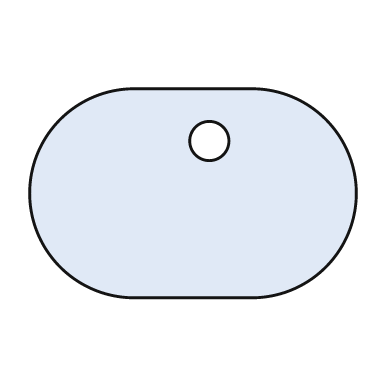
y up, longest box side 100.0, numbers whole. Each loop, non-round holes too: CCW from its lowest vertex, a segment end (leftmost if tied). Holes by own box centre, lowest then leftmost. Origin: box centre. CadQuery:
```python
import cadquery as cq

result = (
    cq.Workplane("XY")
    .moveTo(-18.0, -32.0)
    .lineTo(18.0, -32.0)
    .threePointArc((50.0, 0.0), (18.0, 32.0))
    .lineTo(-18.0, 32.0)
    .threePointArc((-50.0, 0.0), (-18.0, -32.0))
    .close()
    .moveTo(5.0, 16.0)
    .circle(6.0)
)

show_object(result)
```